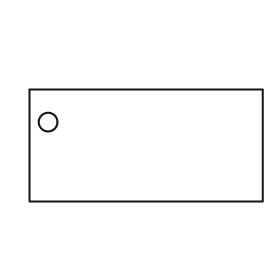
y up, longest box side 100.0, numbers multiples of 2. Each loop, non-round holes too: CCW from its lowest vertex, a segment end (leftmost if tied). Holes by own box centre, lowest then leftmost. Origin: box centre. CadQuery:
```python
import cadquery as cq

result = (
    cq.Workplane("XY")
    .moveTo(-50.0, -24.0)
    .lineTo(50.0, -24.0)
    .lineTo(50.0, 24.0)
    .lineTo(-50.0, 24.0)
    .close()
    .moveTo(-42.0, 10.0)
    .circle(4.0)
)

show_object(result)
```